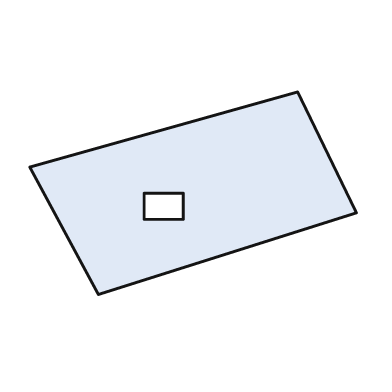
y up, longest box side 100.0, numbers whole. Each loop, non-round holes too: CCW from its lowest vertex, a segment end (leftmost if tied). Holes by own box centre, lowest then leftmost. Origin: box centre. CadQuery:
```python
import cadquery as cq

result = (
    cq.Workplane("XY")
    .moveTo(-29.0, -31.0)
    .lineTo(50.0, -6.0)
    .lineTo(32.0, 31.0)
    .lineTo(-50.0, 8.0)
    .close()
    .moveTo(-15.0, -8.0)
    .lineTo(-3.0, -8.0)
    .lineTo(-3.0, 0.0)
    .lineTo(-15.0, 0.0)
    .close()
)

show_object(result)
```